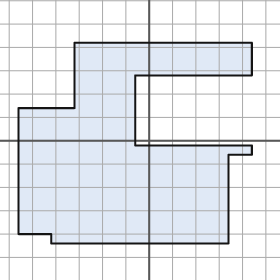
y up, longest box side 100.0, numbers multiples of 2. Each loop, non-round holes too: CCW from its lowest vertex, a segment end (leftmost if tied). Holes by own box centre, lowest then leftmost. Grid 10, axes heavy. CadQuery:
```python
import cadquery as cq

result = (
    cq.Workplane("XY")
    .moveTo(-42.0, -44.0)
    .lineTo(34.0, -44.0)
    .lineTo(34.0, -6.0)
    .lineTo(44.0, -6.0)
    .lineTo(44.0, -2.0)
    .lineTo(-6.0, -2.0)
    .lineTo(-6.0, 28.0)
    .lineTo(44.0, 28.0)
    .lineTo(44.0, 42.0)
    .lineTo(-32.0, 42.0)
    .lineTo(-32.0, 14.0)
    .lineTo(-56.0, 14.0)
    .lineTo(-56.0, -40.0)
    .lineTo(-42.0, -40.0)
    .close()
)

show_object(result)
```